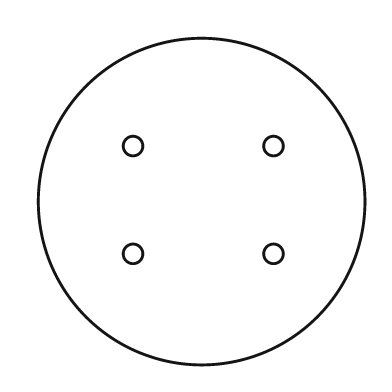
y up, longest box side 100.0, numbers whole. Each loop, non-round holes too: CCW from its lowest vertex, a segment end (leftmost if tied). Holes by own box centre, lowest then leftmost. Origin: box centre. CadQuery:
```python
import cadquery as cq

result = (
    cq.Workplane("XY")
    .moveTo(0.0, 0.0)
    .circle(50.0)
    .moveTo(-21.0, -16.0)
    .circle(3.0)
    .moveTo(22.0, -16.0)
    .circle(3.0)
    .moveTo(-21.0, 17.0)
    .circle(3.0)
    .moveTo(22.0, 17.0)
    .circle(3.0)
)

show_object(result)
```